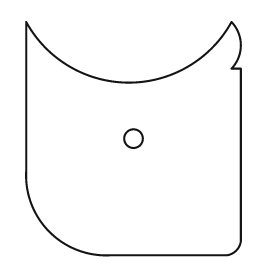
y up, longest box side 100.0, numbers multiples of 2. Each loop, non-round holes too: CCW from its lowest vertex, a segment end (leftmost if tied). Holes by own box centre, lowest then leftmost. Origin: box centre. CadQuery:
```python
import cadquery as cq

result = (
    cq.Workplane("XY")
    .moveTo(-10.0, -50.0)
    .lineTo(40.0, -50.0)
    .threePointArc((44.0, -48.0), (46.0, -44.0))
    .lineTo(46.0, 30.0)
    .lineTo(42.0, 30.0)
    .threePointArc((46.0, 40.0), (42.0, 50.0))
    .threePointArc((-2.0, 24.0), (-46.0, 50.0))
    .lineTo(-46.0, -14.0)
    .threePointArc((-36.0, -40.0), (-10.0, -50.0))
    .close()
    .moveTo(0.0, 0.0)
    .circle(4.0)
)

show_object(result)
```